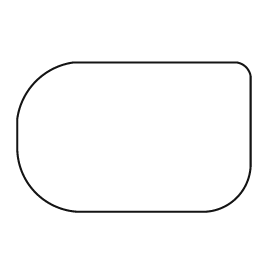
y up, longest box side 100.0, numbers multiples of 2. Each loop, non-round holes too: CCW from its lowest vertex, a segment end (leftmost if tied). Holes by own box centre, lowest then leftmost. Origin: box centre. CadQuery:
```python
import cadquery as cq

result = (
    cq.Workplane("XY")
    .moveTo(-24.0, -32.0)
    .lineTo(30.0, -32.0)
    .threePointArc((44.0, -26.0), (50.0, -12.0))
    .lineTo(50.0, 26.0)
    .threePointArc((48.0, 30.0), (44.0, 32.0))
    .lineTo(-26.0, 32.0)
    .threePointArc((-42.0, 24.0), (-50.0, 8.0))
    .lineTo(-50.0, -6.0)
    .threePointArc((-42.0, -24.0), (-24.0, -32.0))
    .close()
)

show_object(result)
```